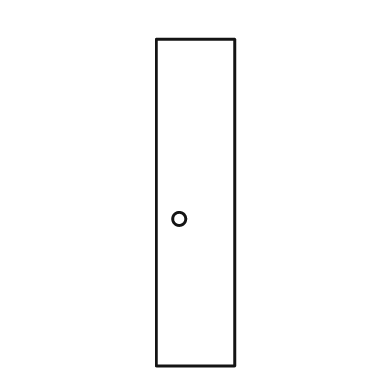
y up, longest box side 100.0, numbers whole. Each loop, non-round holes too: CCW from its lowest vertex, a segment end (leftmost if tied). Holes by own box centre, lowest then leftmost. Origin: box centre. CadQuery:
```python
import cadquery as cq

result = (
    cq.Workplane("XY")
    .moveTo(-12.0, -50.0)
    .lineTo(12.0, -50.0)
    .lineTo(12.0, 50.0)
    .lineTo(-12.0, 50.0)
    .close()
    .moveTo(-5.0, -5.0)
    .circle(2.0)
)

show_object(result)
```